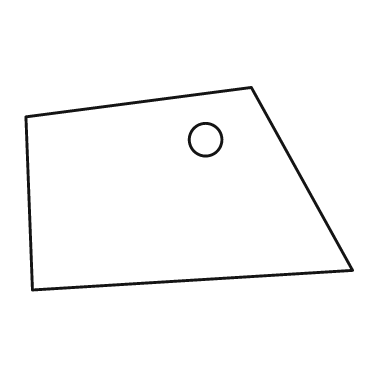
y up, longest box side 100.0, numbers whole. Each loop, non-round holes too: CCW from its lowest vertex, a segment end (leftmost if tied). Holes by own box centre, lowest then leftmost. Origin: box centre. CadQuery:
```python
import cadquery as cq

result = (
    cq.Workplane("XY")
    .moveTo(-48.0, -31.0)
    .lineTo(50.0, -25.0)
    .lineTo(19.0, 31.0)
    .lineTo(-50.0, 22.0)
    .close()
    .moveTo(5.0, 15.0)
    .circle(5.0)
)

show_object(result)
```